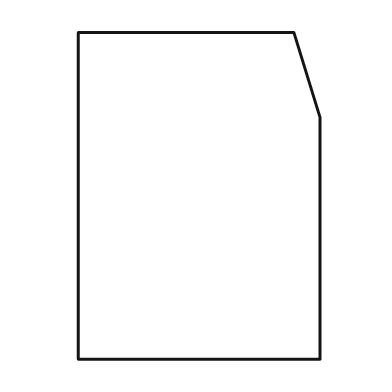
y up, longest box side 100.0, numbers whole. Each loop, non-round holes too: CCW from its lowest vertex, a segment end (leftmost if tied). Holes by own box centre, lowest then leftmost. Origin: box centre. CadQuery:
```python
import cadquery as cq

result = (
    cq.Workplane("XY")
    .moveTo(-37.0, -50.0)
    .lineTo(37.0, -50.0)
    .lineTo(37.0, 24.0)
    .lineTo(29.0, 50.0)
    .lineTo(-37.0, 50.0)
    .close()
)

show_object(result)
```